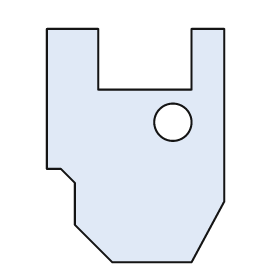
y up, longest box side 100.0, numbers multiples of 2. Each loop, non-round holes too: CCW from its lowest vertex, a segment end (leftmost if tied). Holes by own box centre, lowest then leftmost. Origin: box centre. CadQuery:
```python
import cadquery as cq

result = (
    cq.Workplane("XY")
    .moveTo(-10.0, -50.0)
    .lineTo(24.0, -50.0)
    .lineTo(38.0, -24.0)
    .lineTo(38.0, 50.0)
    .lineTo(24.0, 50.0)
    .lineTo(24.0, 24.0)
    .lineTo(-16.0, 24.0)
    .lineTo(-16.0, 50.0)
    .lineTo(-38.0, 50.0)
    .lineTo(-38.0, -10.0)
    .lineTo(-32.0, -10.0)
    .lineTo(-26.0, -16.0)
    .lineTo(-26.0, -34.0)
    .close()
    .moveTo(16.0, 10.0)
    .circle(8.0)
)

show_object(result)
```